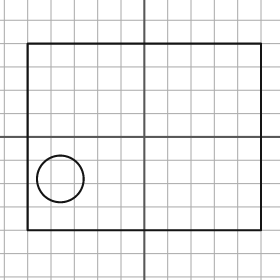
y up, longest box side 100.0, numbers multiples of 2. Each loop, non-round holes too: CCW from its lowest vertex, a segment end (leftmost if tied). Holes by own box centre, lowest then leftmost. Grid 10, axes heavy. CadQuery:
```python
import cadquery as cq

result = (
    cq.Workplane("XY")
    .moveTo(-50.0, -40.0)
    .lineTo(50.0, -40.0)
    .lineTo(50.0, 40.0)
    .lineTo(-50.0, 40.0)
    .close()
    .moveTo(-36.0, -18.0)
    .circle(10.0)
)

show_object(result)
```